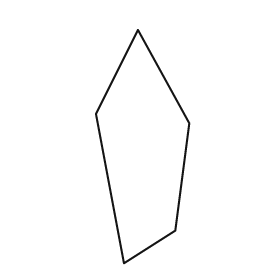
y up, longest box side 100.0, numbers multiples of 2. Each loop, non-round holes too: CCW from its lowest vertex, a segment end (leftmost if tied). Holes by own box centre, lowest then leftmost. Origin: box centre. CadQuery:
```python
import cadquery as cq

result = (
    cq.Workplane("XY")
    .moveTo(-8.0, -50.0)
    .lineTo(14.0, -36.0)
    .lineTo(20.0, 10.0)
    .lineTo(-2.0, 50.0)
    .lineTo(-20.0, 14.0)
    .close()
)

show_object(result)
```